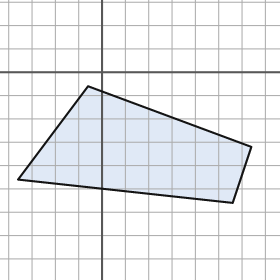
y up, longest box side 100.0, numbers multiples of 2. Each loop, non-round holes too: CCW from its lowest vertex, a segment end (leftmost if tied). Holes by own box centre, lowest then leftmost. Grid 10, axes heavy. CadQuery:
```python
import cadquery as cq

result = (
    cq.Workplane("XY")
    .moveTo(56.0, -56.0)
    .lineTo(64.0, -32.0)
    .lineTo(-6.0, -6.0)
    .lineTo(-36.0, -46.0)
    .close()
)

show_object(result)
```